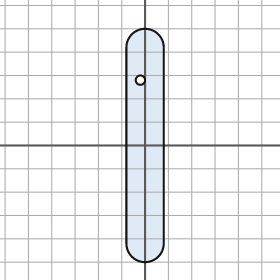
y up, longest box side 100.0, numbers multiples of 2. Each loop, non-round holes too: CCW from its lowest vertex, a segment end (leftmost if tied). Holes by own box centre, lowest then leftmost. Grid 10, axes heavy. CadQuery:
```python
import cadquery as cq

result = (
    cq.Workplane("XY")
    .moveTo(-8.0, -42.0)
    .threePointArc((0.0, -50.0), (8.0, -42.0))
    .lineTo(8.0, 42.0)
    .threePointArc((0.0, 50.0), (-8.0, 42.0))
    .close()
    .moveTo(-2.0, 28.0)
    .circle(2.0)
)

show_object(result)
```